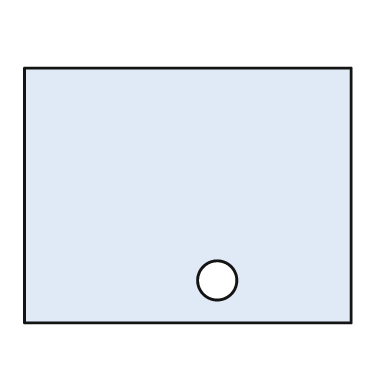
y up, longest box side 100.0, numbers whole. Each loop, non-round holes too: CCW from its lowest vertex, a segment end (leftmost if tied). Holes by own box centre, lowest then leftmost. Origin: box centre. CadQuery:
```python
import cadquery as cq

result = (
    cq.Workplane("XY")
    .moveTo(-50.0, -39.0)
    .lineTo(50.0, -39.0)
    .lineTo(50.0, 39.0)
    .lineTo(-50.0, 39.0)
    .close()
    .moveTo(9.0, -26.0)
    .circle(6.0)
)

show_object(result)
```